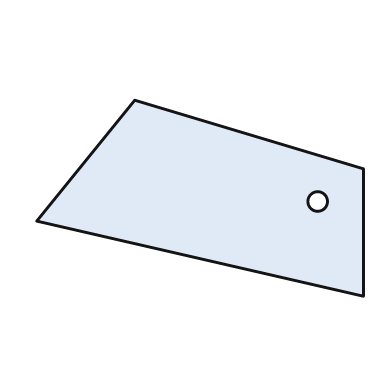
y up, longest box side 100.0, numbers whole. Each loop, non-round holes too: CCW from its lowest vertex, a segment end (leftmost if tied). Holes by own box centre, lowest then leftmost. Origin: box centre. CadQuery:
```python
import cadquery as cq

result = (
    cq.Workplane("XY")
    .moveTo(50.0, -30.0)
    .lineTo(50.0, 9.0)
    .lineTo(-20.0, 30.0)
    .lineTo(-50.0, -7.0)
    .close()
    .moveTo(36.0, -1.0)
    .circle(3.0)
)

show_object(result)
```